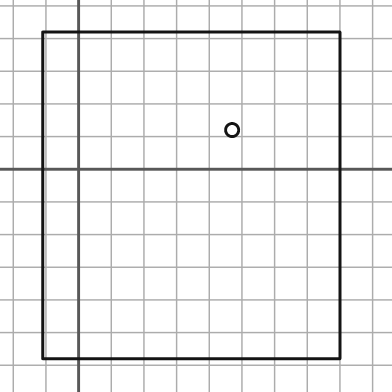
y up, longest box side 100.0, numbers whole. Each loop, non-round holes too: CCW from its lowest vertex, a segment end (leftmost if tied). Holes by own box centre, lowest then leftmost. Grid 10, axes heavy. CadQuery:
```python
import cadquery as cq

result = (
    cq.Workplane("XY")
    .moveTo(-11.0, -58.0)
    .lineTo(80.0, -58.0)
    .lineTo(80.0, 42.0)
    .lineTo(-11.0, 42.0)
    .close()
    .moveTo(47.0, 12.0)
    .circle(2.0)
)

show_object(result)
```